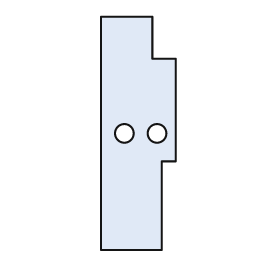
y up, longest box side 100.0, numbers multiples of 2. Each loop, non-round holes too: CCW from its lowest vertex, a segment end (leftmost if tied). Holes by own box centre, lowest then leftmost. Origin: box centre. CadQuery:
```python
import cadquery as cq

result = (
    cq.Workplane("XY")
    .moveTo(-16.0, -50.0)
    .lineTo(10.0, -50.0)
    .lineTo(10.0, -12.0)
    .lineTo(16.0, -12.0)
    .lineTo(16.0, 32.0)
    .lineTo(6.0, 32.0)
    .lineTo(6.0, 50.0)
    .lineTo(-16.0, 50.0)
    .close()
    .moveTo(-6.0, 0.0)
    .circle(4.0)
    .moveTo(8.0, 0.0)
    .circle(4.0)
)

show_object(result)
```